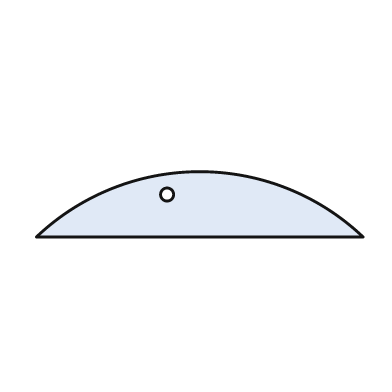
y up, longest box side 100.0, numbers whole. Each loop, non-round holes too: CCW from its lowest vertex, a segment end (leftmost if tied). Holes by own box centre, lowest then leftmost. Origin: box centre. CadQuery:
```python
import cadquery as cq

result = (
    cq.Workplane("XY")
    .moveTo(-50.0, -10.0)
    .lineTo(50.0, -10.0)
    .threePointArc((0.0, 10.0), (-50.0, -10.0))
    .close()
    .moveTo(-10.0, 3.0)
    .circle(2.0)
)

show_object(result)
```